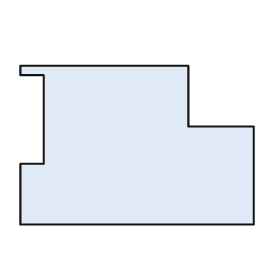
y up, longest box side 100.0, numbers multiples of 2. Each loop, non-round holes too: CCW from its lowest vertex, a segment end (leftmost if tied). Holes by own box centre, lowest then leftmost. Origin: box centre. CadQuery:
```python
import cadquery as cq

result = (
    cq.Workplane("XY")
    .moveTo(-50.0, -34.0)
    .lineTo(50.0, -34.0)
    .lineTo(50.0, 8.0)
    .lineTo(22.0, 8.0)
    .lineTo(22.0, 34.0)
    .lineTo(-50.0, 34.0)
    .lineTo(-50.0, 30.0)
    .lineTo(-40.0, 30.0)
    .lineTo(-40.0, -8.0)
    .lineTo(-50.0, -8.0)
    .close()
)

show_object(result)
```